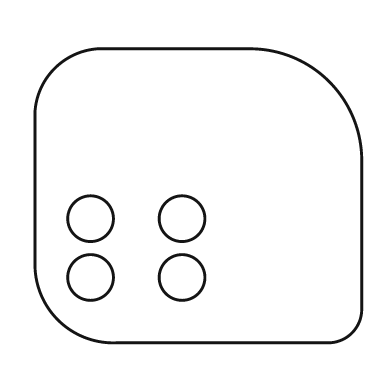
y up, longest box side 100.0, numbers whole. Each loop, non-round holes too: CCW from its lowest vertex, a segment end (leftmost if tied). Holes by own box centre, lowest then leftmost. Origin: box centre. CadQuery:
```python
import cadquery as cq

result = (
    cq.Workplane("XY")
    .moveTo(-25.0, -45.0)
    .lineTo(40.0, -45.0)
    .threePointArc((47.0, -42.0), (50.0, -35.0))
    .lineTo(50.0, 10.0)
    .threePointArc((40.0, 35.0), (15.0, 45.0))
    .lineTo(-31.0, 45.0)
    .threePointArc((-44.0, 39.0), (-50.0, 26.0))
    .lineTo(-50.0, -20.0)
    .threePointArc((-43.0, -38.0), (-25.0, -45.0))
    .close()
    .moveTo(-33.0, -25.0)
    .circle(7.0)
    .moveTo(-5.0, -25.0)
    .circle(7.0)
    .moveTo(-33.0, -7.0)
    .circle(7.0)
    .moveTo(-5.0, -7.0)
    .circle(7.0)
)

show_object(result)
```